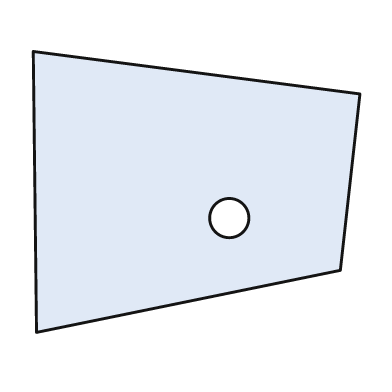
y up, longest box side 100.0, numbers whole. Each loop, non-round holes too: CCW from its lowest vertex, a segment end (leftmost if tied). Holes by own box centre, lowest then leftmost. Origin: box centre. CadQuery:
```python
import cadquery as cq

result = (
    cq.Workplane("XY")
    .moveTo(-49.0, -43.0)
    .lineTo(44.0, -24.0)
    .lineTo(50.0, 30.0)
    .lineTo(-50.0, 43.0)
    .close()
    .moveTo(10.0, -8.0)
    .circle(6.0)
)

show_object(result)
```